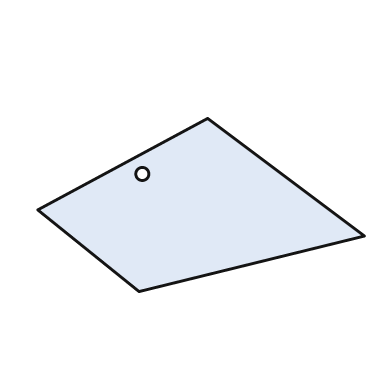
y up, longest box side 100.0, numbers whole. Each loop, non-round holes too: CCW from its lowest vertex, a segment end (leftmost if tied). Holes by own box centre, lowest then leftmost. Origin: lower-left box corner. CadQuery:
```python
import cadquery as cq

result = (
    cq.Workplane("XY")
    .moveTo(31.0, 0.0)
    .lineTo(100.0, 17.0)
    .lineTo(52.0, 53.0)
    .lineTo(0.0, 25.0)
    .close()
    .moveTo(32.0, 36.0)
    .circle(2.0)
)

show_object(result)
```